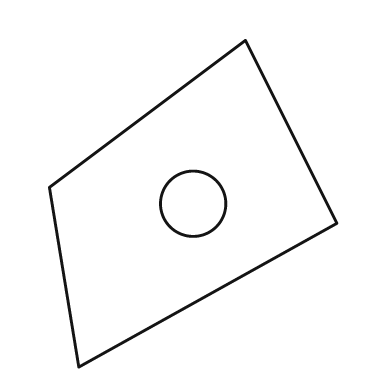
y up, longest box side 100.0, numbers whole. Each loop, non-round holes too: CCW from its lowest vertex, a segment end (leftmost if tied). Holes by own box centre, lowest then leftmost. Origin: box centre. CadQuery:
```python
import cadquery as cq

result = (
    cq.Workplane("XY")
    .moveTo(-35.0, -50.0)
    .lineTo(44.0, -6.0)
    .lineTo(16.0, 50.0)
    .lineTo(-44.0, 5.0)
    .close()
    .moveTo(0.0, 0.0)
    .circle(10.0)
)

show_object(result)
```